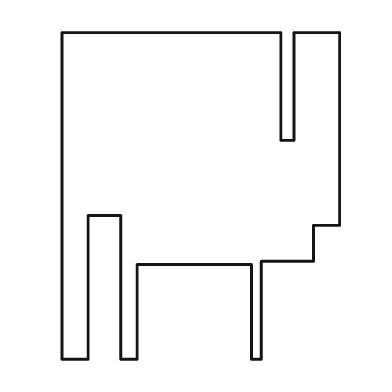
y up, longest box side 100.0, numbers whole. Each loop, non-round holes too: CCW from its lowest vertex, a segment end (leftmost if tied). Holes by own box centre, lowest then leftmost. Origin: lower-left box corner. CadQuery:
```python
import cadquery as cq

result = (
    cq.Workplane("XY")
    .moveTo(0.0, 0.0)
    .lineTo(8.0, 0.0)
    .lineTo(8.0, 44.0)
    .lineTo(18.0, 44.0)
    .lineTo(18.0, 0.0)
    .lineTo(23.0, 0.0)
    .lineTo(23.0, 29.0)
    .lineTo(58.0, 29.0)
    .lineTo(58.0, 0.0)
    .lineTo(61.0, 0.0)
    .lineTo(61.0, 30.0)
    .lineTo(77.0, 30.0)
    .lineTo(77.0, 41.0)
    .lineTo(85.0, 41.0)
    .lineTo(85.0, 100.0)
    .lineTo(71.0, 100.0)
    .lineTo(71.0, 67.0)
    .lineTo(67.0, 67.0)
    .lineTo(67.0, 100.0)
    .lineTo(0.0, 100.0)
    .close()
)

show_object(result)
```